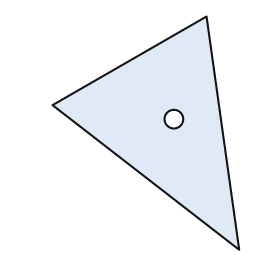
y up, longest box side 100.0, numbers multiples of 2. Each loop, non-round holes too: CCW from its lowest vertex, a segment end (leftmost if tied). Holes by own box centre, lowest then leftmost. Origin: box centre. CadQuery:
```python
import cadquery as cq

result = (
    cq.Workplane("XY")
    .moveTo(40.0, -50.0)
    .lineTo(26.0, 50.0)
    .lineTo(-40.0, 12.0)
    .close()
    .moveTo(12.0, 6.0)
    .circle(4.0)
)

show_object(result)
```